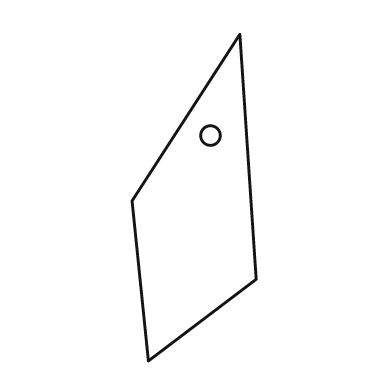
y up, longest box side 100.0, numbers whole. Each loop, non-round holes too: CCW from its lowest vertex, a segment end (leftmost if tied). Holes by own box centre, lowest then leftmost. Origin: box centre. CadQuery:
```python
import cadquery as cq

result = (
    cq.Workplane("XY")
    .moveTo(-14.0, -50.0)
    .lineTo(19.0, -25.0)
    .lineTo(14.0, 50.0)
    .lineTo(-19.0, -1.0)
    .close()
    .moveTo(5.0, 19.0)
    .circle(3.0)
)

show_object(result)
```